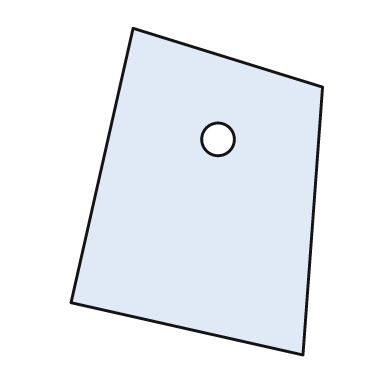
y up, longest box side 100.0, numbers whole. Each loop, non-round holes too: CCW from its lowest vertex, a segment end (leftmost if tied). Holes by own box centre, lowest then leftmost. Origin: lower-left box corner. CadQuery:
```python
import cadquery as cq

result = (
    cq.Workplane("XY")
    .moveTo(71.0, 0.0)
    .lineTo(77.0, 82.0)
    .lineTo(19.0, 100.0)
    .lineTo(0.0, 16.0)
    .close()
    .moveTo(45.0, 66.0)
    .circle(5.0)
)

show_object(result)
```